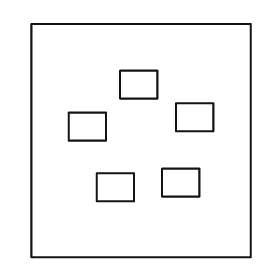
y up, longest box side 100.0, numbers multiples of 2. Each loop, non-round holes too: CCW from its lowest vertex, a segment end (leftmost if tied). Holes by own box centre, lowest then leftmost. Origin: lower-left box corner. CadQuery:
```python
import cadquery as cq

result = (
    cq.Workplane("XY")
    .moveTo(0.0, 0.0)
    .lineTo(94.0, 0.0)
    .lineTo(94.0, 100.0)
    .lineTo(0.0, 100.0)
    .close()
    .moveTo(28.0, 24.0)
    .lineTo(44.0, 24.0)
    .lineTo(44.0, 36.0)
    .lineTo(28.0, 36.0)
    .close()
    .moveTo(56.0, 26.0)
    .lineTo(72.0, 26.0)
    .lineTo(72.0, 38.0)
    .lineTo(56.0, 38.0)
    .close()
    .moveTo(16.0, 50.0)
    .lineTo(32.0, 50.0)
    .lineTo(32.0, 62.0)
    .lineTo(16.0, 62.0)
    .close()
    .moveTo(62.0, 54.0)
    .lineTo(78.0, 54.0)
    .lineTo(78.0, 66.0)
    .lineTo(62.0, 66.0)
    .close()
    .moveTo(38.0, 68.0)
    .lineTo(54.0, 68.0)
    .lineTo(54.0, 80.0)
    .lineTo(38.0, 80.0)
    .close()
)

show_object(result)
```